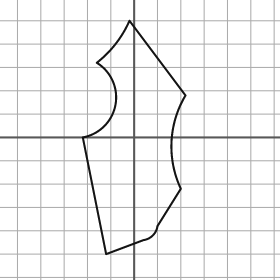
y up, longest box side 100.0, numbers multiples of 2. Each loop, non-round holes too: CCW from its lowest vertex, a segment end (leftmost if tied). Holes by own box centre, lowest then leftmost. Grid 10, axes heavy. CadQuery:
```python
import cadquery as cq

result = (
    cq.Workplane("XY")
    .moveTo(-12.0, -50.0)
    .lineTo(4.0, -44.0)
    .threePointArc((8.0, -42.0), (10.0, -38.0))
    .lineTo(20.0, -22.0)
    .threePointArc((16.0, -2.0), (22.0, 18.0))
    .lineTo(-2.0, 50.0)
    .threePointArc((-8.0, 40.0), (-16.0, 32.0))
    .threePointArc((-8.0, 14.0), (-22.0, 0.0))
    .close()
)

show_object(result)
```